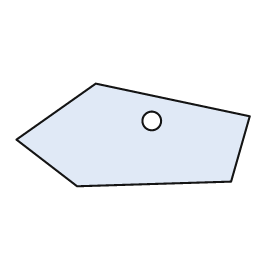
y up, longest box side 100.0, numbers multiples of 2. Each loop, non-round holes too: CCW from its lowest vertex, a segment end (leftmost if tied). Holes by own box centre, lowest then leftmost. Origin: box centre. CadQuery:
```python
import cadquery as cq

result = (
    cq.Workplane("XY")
    .moveTo(-24.0, -22.0)
    .lineTo(42.0, -20.0)
    .lineTo(50.0, 8.0)
    .lineTo(-16.0, 22.0)
    .lineTo(-50.0, -2.0)
    .close()
    .moveTo(8.0, 6.0)
    .circle(4.0)
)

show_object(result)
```